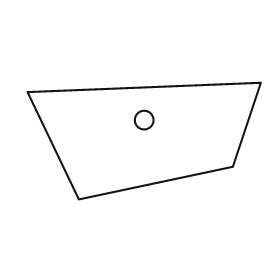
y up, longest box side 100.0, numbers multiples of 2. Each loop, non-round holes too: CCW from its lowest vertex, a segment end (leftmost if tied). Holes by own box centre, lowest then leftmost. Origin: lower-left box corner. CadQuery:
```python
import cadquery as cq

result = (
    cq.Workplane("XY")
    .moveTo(22.0, 0.0)
    .lineTo(88.0, 14.0)
    .lineTo(100.0, 50.0)
    .lineTo(0.0, 46.0)
    .close()
    .moveTo(50.0, 34.0)
    .circle(4.0)
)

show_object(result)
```